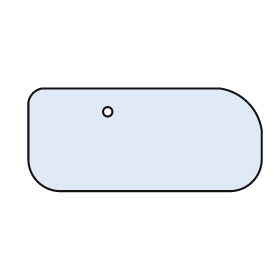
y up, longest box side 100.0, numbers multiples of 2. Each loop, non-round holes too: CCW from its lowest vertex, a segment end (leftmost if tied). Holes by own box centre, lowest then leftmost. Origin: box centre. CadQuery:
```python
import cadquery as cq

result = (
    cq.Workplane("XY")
    .moveTo(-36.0, -22.0)
    .lineTo(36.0, -22.0)
    .threePointArc((46.0, -18.0), (50.0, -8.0))
    .lineTo(50.0, 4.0)
    .threePointArc((44.0, 16.0), (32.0, 22.0))
    .lineTo(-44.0, 22.0)
    .threePointArc((-48.0, 20.0), (-50.0, 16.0))
    .lineTo(-50.0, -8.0)
    .threePointArc((-46.0, -18.0), (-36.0, -22.0))
    .close()
    .moveTo(-16.0, 12.0)
    .circle(2.0)
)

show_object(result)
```